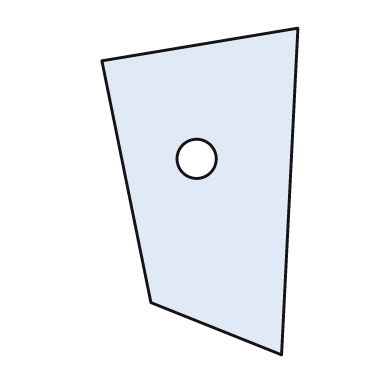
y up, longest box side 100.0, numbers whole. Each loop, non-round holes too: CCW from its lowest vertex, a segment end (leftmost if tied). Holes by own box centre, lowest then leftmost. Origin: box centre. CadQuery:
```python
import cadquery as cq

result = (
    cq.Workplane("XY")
    .moveTo(25.0, -50.0)
    .lineTo(30.0, 50.0)
    .lineTo(-30.0, 40.0)
    .lineTo(-15.0, -34.0)
    .close()
    .moveTo(-1.0, 10.0)
    .circle(6.0)
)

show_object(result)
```